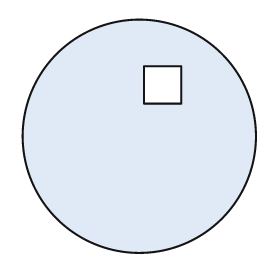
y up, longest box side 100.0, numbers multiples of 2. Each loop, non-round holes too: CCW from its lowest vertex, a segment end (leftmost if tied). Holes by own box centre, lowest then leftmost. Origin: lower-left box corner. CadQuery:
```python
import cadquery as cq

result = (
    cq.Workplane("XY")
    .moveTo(50.0, 50.0)
    .circle(50.0)
    .moveTo(52.0, 64.0)
    .lineTo(68.0, 64.0)
    .lineTo(68.0, 80.0)
    .lineTo(52.0, 80.0)
    .close()
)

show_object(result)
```